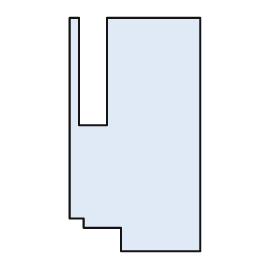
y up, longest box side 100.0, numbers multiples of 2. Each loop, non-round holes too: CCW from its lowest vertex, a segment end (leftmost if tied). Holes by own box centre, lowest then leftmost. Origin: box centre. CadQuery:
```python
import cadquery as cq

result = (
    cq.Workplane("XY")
    .moveTo(-6.0, -50.0)
    .lineTo(28.0, -50.0)
    .lineTo(28.0, 50.0)
    .lineTo(-12.0, 50.0)
    .lineTo(-12.0, 4.0)
    .lineTo(-24.0, 4.0)
    .lineTo(-24.0, 50.0)
    .lineTo(-28.0, 50.0)
    .lineTo(-28.0, -36.0)
    .lineTo(-22.0, -36.0)
    .lineTo(-22.0, -40.0)
    .lineTo(-6.0, -40.0)
    .close()
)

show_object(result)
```